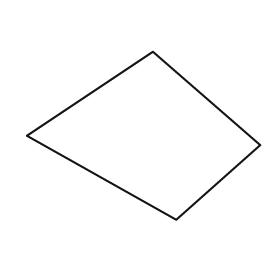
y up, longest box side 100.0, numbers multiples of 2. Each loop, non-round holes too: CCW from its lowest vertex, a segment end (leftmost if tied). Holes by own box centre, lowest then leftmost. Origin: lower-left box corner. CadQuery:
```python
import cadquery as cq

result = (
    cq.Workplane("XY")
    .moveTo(64.0, 0.0)
    .lineTo(100.0, 32.0)
    .lineTo(54.0, 72.0)
    .lineTo(0.0, 36.0)
    .close()
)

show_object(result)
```